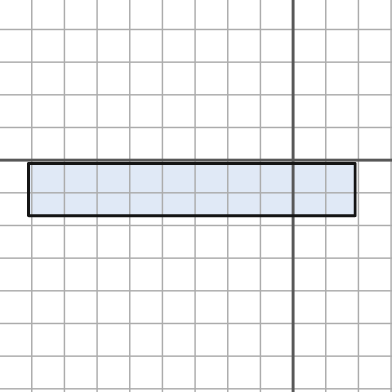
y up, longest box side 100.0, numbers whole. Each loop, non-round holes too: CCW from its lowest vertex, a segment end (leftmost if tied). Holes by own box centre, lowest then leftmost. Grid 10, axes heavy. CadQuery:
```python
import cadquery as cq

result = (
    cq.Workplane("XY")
    .moveTo(-81.0, -17.0)
    .lineTo(19.0, -17.0)
    .lineTo(19.0, -1.0)
    .lineTo(-81.0, -1.0)
    .close()
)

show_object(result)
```